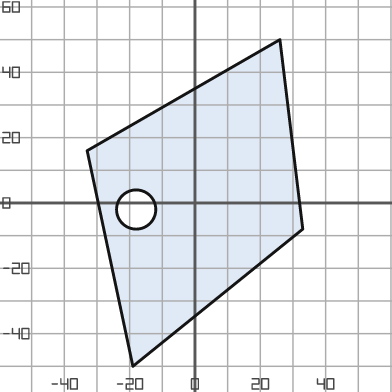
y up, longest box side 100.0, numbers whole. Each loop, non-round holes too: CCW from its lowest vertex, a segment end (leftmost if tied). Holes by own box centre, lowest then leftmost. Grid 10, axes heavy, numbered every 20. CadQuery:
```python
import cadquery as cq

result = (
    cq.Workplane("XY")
    .moveTo(-19.0, -50.0)
    .lineTo(33.0, -8.0)
    .lineTo(26.0, 50.0)
    .lineTo(-33.0, 16.0)
    .close()
    .moveTo(-18.0, -2.0)
    .circle(6.0)
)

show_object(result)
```